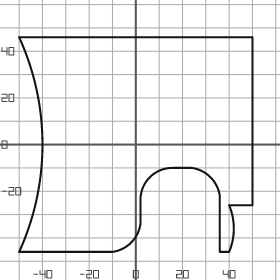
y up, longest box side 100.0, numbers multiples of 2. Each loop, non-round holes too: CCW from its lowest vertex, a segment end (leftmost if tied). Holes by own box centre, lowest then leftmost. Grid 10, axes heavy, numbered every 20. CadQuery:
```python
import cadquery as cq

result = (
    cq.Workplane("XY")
    .moveTo(-50.0, -46.0)
    .lineTo(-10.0, -46.0)
    .threePointArc((-2.0, -42.0), (2.0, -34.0))
    .lineTo(2.0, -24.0)
    .threePointArc((6.0, -14.0), (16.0, -10.0))
    .lineTo(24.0, -10.0)
    .threePointArc((32.0, -14.0), (36.0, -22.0))
    .lineTo(36.0, -46.0)
    .lineTo(40.0, -46.0)
    .threePointArc((42.0, -36.0), (40.0, -26.0))
    .lineTo(50.0, -26.0)
    .lineTo(50.0, 46.0)
    .lineTo(-50.0, 46.0)
    .threePointArc((-40.0, 0.0), (-50.0, -46.0))
    .close()
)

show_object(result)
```